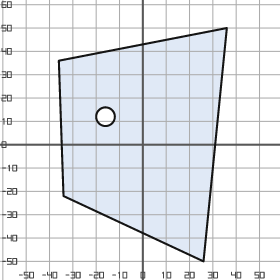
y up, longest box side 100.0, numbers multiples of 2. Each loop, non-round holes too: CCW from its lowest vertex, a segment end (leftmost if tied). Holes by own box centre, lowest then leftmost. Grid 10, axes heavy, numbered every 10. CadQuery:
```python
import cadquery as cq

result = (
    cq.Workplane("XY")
    .moveTo(26.0, -50.0)
    .lineTo(36.0, 50.0)
    .lineTo(-36.0, 36.0)
    .lineTo(-34.0, -22.0)
    .close()
    .moveTo(-16.0, 12.0)
    .circle(4.0)
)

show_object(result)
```